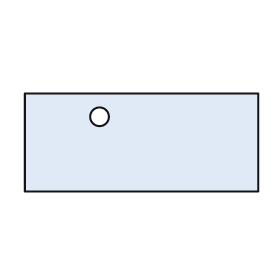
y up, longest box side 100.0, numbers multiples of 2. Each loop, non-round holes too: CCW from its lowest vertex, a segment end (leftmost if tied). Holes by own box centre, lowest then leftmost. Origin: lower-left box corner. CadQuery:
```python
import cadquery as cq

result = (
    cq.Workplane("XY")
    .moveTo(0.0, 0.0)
    .lineTo(100.0, 0.0)
    .lineTo(100.0, 42.0)
    .lineTo(0.0, 42.0)
    .close()
    .moveTo(32.0, 32.0)
    .circle(4.0)
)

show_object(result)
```